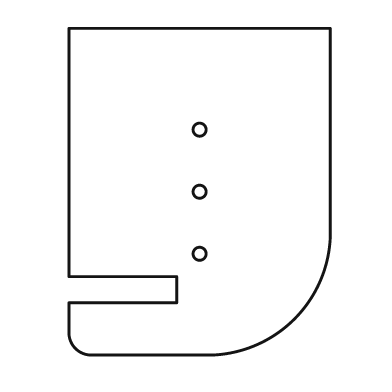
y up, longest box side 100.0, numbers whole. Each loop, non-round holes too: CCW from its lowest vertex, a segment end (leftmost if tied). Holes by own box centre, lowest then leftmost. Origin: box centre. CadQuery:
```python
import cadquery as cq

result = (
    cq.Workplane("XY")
    .moveTo(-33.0, -50.0)
    .lineTo(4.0, -50.0)
    .threePointArc((29.0, -39.0), (40.0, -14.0))
    .lineTo(40.0, 50.0)
    .lineTo(-40.0, 50.0)
    .lineTo(-40.0, -26.0)
    .lineTo(-7.0, -26.0)
    .lineTo(-7.0, -34.0)
    .lineTo(-40.0, -34.0)
    .lineTo(-40.0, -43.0)
    .threePointArc((-38.0, -48.0), (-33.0, -50.0))
    .close()
    .moveTo(0.0, -19.0)
    .circle(2.0)
    .moveTo(0.0, 0.0)
    .circle(2.0)
    .moveTo(0.0, 19.0)
    .circle(2.0)
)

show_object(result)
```